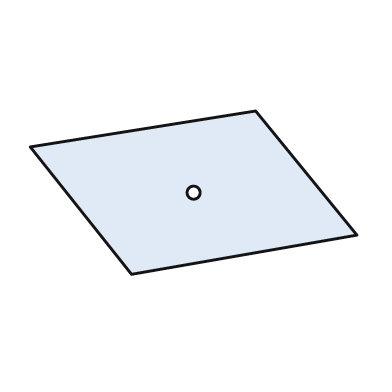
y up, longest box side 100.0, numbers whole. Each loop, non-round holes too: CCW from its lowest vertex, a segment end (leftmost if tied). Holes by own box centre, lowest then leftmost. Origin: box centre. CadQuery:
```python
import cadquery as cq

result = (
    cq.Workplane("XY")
    .moveTo(-19.0, -25.0)
    .lineTo(50.0, -13.0)
    .lineTo(19.0, 25.0)
    .lineTo(-50.0, 14.0)
    .close()
    .moveTo(0.0, 0.0)
    .circle(2.0)
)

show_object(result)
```